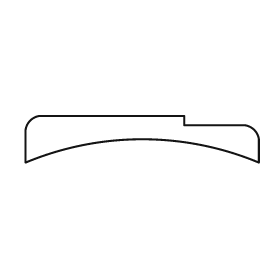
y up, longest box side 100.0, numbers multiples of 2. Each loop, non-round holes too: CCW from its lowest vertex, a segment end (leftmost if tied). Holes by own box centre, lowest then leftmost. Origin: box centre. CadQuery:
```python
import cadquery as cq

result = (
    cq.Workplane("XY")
    .moveTo(-50.0, -10.0)
    .threePointArc((0.0, 0.0), (50.0, -10.0))
    .lineTo(50.0, 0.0)
    .threePointArc((48.0, 4.0), (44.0, 6.0))
    .lineTo(18.0, 6.0)
    .lineTo(18.0, 10.0)
    .lineTo(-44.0, 10.0)
    .threePointArc((-48.0, 8.0), (-50.0, 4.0))
    .close()
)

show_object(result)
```